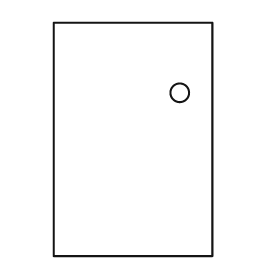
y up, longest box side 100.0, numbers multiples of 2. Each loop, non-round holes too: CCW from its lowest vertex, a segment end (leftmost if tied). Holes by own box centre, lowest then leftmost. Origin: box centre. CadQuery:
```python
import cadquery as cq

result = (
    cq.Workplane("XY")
    .moveTo(-34.0, -50.0)
    .lineTo(34.0, -50.0)
    .lineTo(34.0, 50.0)
    .lineTo(-34.0, 50.0)
    .close()
    .moveTo(20.0, 20.0)
    .circle(4.0)
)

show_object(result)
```